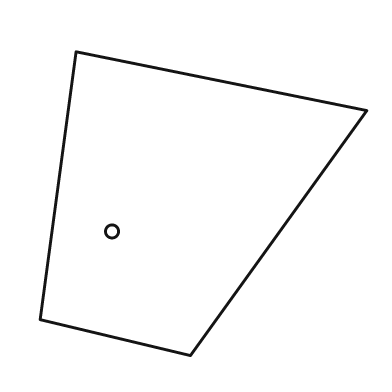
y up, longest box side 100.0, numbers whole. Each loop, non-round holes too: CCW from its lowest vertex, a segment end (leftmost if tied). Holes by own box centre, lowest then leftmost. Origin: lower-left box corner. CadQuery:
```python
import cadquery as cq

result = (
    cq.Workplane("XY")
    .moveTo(46.0, 0.0)
    .lineTo(100.0, 75.0)
    .lineTo(11.0, 93.0)
    .lineTo(0.0, 11.0)
    .close()
    .moveTo(22.0, 38.0)
    .circle(2.0)
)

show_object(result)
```